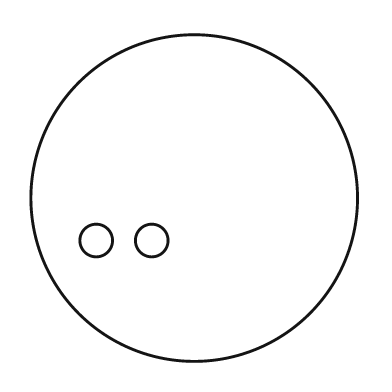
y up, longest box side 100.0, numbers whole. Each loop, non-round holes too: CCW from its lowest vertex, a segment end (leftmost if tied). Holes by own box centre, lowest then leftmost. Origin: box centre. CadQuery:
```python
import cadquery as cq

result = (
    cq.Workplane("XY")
    .moveTo(0.0, 0.0)
    .circle(50.0)
    .moveTo(-30.0, -13.0)
    .circle(5.0)
    .moveTo(-13.0, -13.0)
    .circle(5.0)
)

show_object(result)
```